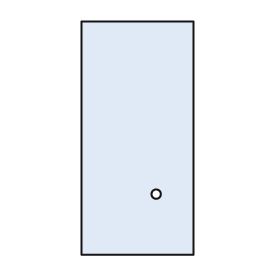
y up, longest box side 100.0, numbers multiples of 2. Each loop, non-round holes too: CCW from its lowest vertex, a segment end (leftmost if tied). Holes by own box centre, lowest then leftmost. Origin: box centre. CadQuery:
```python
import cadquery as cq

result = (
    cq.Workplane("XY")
    .moveTo(-24.0, -50.0)
    .lineTo(24.0, -50.0)
    .lineTo(24.0, 50.0)
    .lineTo(-24.0, 50.0)
    .close()
    .moveTo(8.0, -24.0)
    .circle(2.0)
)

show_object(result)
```